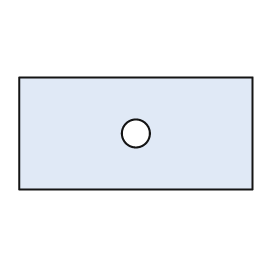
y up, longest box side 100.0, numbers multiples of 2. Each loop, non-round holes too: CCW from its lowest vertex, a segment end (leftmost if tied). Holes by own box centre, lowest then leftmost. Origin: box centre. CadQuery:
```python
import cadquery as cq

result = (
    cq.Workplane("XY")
    .moveTo(-50.0, -24.0)
    .lineTo(50.0, -24.0)
    .lineTo(50.0, 24.0)
    .lineTo(-50.0, 24.0)
    .close()
    .moveTo(0.0, 0.0)
    .circle(6.0)
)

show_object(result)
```